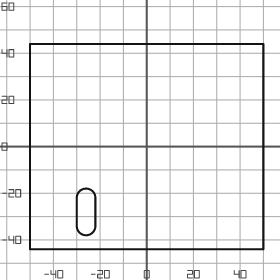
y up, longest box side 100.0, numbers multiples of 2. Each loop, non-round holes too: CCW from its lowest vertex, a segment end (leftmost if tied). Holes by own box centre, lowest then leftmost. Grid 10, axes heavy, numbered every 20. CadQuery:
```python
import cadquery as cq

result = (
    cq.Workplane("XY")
    .moveTo(-50.0, -44.0)
    .lineTo(50.0, -44.0)
    .lineTo(50.0, 44.0)
    .lineTo(-50.0, 44.0)
    .close()
    .moveTo(-30.0, -34.0)
    .threePointArc((-26.0, -38.0), (-22.0, -34.0))
    .lineTo(-22.0, -22.0)
    .threePointArc((-26.0, -18.0), (-30.0, -22.0))
    .close()
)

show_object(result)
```